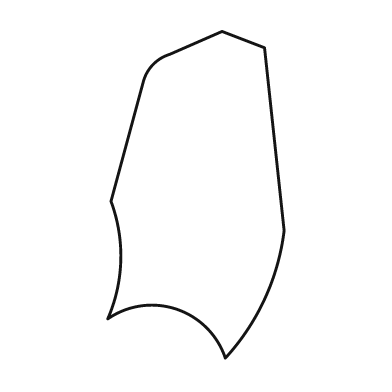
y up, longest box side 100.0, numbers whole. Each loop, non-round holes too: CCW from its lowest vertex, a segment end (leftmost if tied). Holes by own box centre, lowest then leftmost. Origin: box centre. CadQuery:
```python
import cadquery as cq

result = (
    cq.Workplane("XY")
    .moveTo(9.0, -50.0)
    .threePointArc((21.0, -32.0), (27.0, -11.0))
    .lineTo(21.0, 45.0)
    .lineTo(8.0, 50.0)
    .lineTo(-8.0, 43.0)
    .threePointArc((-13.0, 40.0), (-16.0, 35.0))
    .lineTo(-26.0, -2.0)
    .threePointArc((-23.0, -20.0), (-27.0, -38.0))
    .threePointArc((-6.0, -35.0), (9.0, -50.0))
    .close()
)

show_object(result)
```